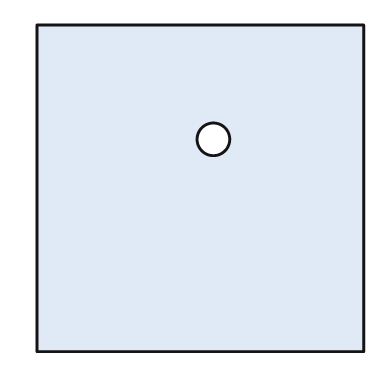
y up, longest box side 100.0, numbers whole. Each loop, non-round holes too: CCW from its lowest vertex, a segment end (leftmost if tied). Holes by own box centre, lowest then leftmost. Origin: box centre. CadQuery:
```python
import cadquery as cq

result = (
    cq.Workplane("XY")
    .moveTo(-50.0, -50.0)
    .lineTo(50.0, -50.0)
    .lineTo(50.0, 50.0)
    .lineTo(-50.0, 50.0)
    .close()
    .moveTo(4.0, 15.0)
    .circle(5.0)
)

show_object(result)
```